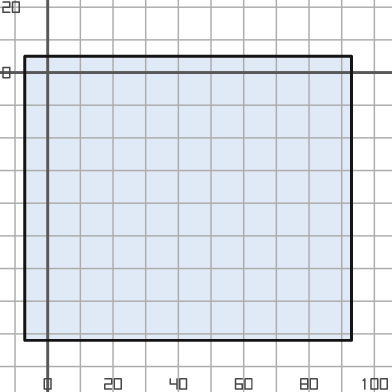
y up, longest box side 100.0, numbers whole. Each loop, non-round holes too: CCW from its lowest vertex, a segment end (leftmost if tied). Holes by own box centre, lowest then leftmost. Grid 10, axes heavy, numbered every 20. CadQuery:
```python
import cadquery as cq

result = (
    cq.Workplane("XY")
    .moveTo(-7.0, -82.0)
    .lineTo(93.0, -82.0)
    .lineTo(93.0, 5.0)
    .lineTo(-7.0, 5.0)
    .close()
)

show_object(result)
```